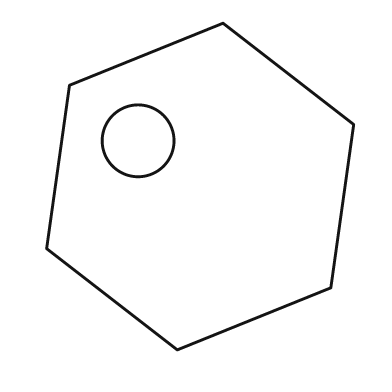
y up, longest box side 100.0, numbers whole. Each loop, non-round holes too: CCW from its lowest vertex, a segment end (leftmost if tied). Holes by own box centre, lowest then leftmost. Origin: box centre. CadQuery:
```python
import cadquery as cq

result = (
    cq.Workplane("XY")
    .moveTo(-7.0, -50.0)
    .lineTo(40.0, -31.0)
    .lineTo(47.0, 19.0)
    .lineTo(7.0, 50.0)
    .lineTo(-40.0, 31.0)
    .lineTo(-47.0, -19.0)
    .close()
    .moveTo(-19.0, 14.0)
    .circle(11.0)
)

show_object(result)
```